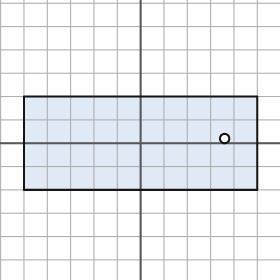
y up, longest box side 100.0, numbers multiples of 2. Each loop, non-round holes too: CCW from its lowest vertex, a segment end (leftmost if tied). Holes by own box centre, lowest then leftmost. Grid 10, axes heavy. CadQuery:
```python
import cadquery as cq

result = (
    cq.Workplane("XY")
    .moveTo(-50.0, -20.0)
    .lineTo(50.0, -20.0)
    .lineTo(50.0, 20.0)
    .lineTo(-50.0, 20.0)
    .close()
    .moveTo(36.0, 2.0)
    .circle(2.0)
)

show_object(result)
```